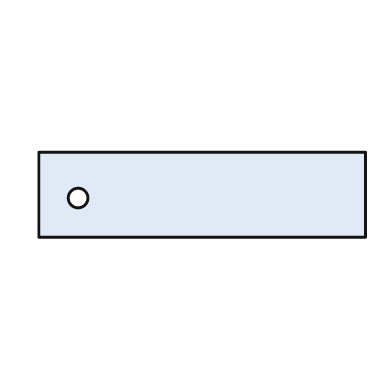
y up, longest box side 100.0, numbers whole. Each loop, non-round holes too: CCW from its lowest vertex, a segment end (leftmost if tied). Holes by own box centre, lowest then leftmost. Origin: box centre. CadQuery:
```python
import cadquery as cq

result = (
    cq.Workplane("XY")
    .moveTo(-50.0, -13.0)
    .lineTo(50.0, -13.0)
    .lineTo(50.0, 13.0)
    .lineTo(-50.0, 13.0)
    .close()
    .moveTo(-38.0, -1.0)
    .circle(3.0)
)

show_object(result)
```